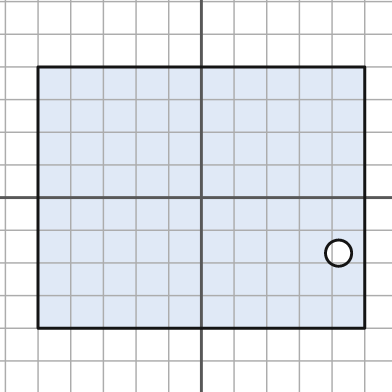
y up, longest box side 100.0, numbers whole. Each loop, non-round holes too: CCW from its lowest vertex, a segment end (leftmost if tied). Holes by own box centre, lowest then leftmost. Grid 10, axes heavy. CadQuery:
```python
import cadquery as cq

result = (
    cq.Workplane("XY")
    .moveTo(-50.0, -40.0)
    .lineTo(50.0, -40.0)
    .lineTo(50.0, 40.0)
    .lineTo(-50.0, 40.0)
    .close()
    .moveTo(42.0, -17.0)
    .circle(4.0)
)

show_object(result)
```